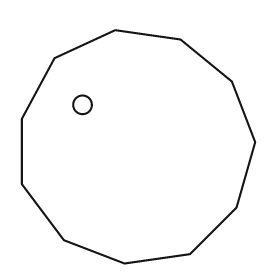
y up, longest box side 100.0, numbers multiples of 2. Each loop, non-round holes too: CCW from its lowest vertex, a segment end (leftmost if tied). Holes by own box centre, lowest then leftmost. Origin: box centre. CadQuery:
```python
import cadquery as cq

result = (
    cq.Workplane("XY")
    .moveTo(-6.0, -50.0)
    .lineTo(22.0, -46.0)
    .lineTo(42.0, -26.0)
    .lineTo(50.0, 2.0)
    .lineTo(40.0, 28.0)
    .lineTo(18.0, 46.0)
    .lineTo(-10.0, 50.0)
    .lineTo(-36.0, 38.0)
    .lineTo(-50.0, 12.0)
    .lineTo(-50.0, -16.0)
    .lineTo(-32.0, -40.0)
    .close()
    .moveTo(-24.0, 18.0)
    .circle(4.0)
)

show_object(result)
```